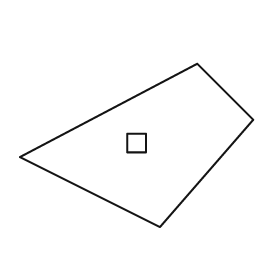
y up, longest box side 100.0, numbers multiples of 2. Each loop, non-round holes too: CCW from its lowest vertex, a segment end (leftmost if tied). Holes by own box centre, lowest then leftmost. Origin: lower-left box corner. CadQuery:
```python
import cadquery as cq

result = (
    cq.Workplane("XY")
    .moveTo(60.0, 0.0)
    .lineTo(100.0, 46.0)
    .lineTo(76.0, 70.0)
    .lineTo(0.0, 30.0)
    .close()
    .moveTo(46.0, 32.0)
    .lineTo(54.0, 32.0)
    .lineTo(54.0, 40.0)
    .lineTo(46.0, 40.0)
    .close()
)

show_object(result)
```